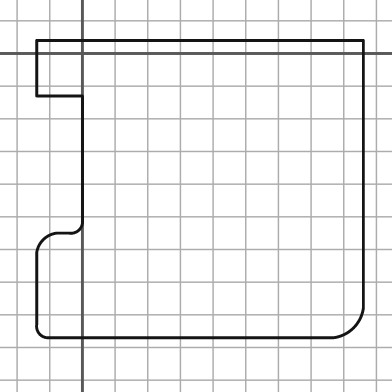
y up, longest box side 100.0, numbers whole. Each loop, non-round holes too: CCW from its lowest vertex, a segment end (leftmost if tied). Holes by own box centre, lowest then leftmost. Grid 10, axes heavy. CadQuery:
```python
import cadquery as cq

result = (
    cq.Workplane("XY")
    .moveTo(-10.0, -87.0)
    .lineTo(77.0, -87.0)
    .threePointArc((83.0, -84.0), (86.0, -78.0))
    .lineTo(86.0, 4.0)
    .lineTo(-14.0, 4.0)
    .lineTo(-14.0, -13.0)
    .lineTo(0.0, -13.0)
    .lineTo(0.0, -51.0)
    .threePointArc((-1.0, -54.0), (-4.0, -55.0))
    .lineTo(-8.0, -55.0)
    .threePointArc((-12.0, -57.0), (-14.0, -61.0))
    .lineTo(-14.0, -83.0)
    .threePointArc((-13.0, -86.0), (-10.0, -87.0))
    .close()
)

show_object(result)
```